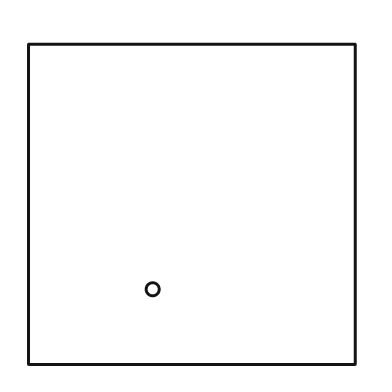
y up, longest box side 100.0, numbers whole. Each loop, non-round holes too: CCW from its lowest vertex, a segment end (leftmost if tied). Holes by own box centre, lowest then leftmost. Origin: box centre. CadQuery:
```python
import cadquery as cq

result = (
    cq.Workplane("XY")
    .moveTo(-50.0, -49.0)
    .lineTo(50.0, -49.0)
    .lineTo(50.0, 49.0)
    .lineTo(-50.0, 49.0)
    .close()
    .moveTo(-12.0, -26.0)
    .circle(2.0)
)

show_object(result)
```